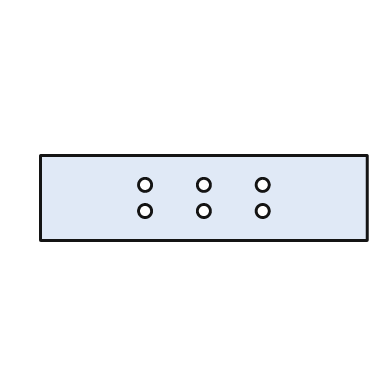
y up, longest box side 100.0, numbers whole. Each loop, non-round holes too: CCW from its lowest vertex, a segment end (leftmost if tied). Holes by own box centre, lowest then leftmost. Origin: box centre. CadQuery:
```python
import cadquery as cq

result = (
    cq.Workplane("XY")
    .moveTo(-50.0, -13.0)
    .lineTo(50.0, -13.0)
    .lineTo(50.0, 13.0)
    .lineTo(-50.0, 13.0)
    .close()
    .moveTo(-18.0, -4.0)
    .circle(2.0)
    .moveTo(0.0, -4.0)
    .circle(2.0)
    .moveTo(18.0, -4.0)
    .circle(2.0)
    .moveTo(-18.0, 4.0)
    .circle(2.0)
    .moveTo(0.0, 4.0)
    .circle(2.0)
    .moveTo(18.0, 4.0)
    .circle(2.0)
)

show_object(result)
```